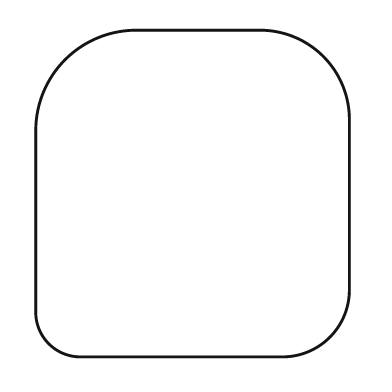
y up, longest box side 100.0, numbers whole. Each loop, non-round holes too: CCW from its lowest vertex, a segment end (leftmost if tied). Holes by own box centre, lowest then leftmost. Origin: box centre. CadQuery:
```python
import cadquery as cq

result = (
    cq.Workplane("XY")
    .moveTo(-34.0, -50.0)
    .lineTo(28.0, -50.0)
    .threePointArc((42.0, -44.0), (48.0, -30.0))
    .lineTo(48.0, 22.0)
    .threePointArc((40.0, 42.0), (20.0, 50.0))
    .lineTo(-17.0, 50.0)
    .threePointArc((-39.0, 41.0), (-48.0, 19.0))
    .lineTo(-48.0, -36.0)
    .threePointArc((-44.0, -46.0), (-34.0, -50.0))
    .close()
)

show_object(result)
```